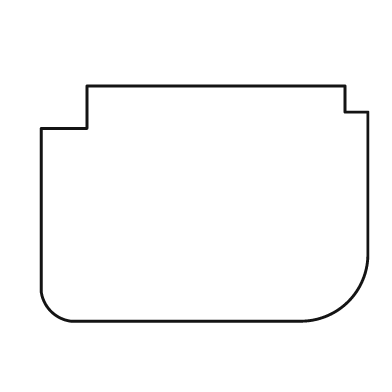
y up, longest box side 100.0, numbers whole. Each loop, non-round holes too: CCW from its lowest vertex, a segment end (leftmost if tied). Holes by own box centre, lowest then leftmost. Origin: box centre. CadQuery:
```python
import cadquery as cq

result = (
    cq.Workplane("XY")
    .moveTo(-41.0, -36.0)
    .lineTo(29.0, -36.0)
    .threePointArc((44.0, -30.0), (50.0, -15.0))
    .lineTo(50.0, 28.0)
    .lineTo(43.0, 28.0)
    .lineTo(43.0, 36.0)
    .lineTo(-36.0, 36.0)
    .lineTo(-36.0, 23.0)
    .lineTo(-50.0, 23.0)
    .lineTo(-50.0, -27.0)
    .threePointArc((-47.0, -33.0), (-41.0, -36.0))
    .close()
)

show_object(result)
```